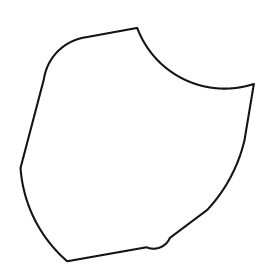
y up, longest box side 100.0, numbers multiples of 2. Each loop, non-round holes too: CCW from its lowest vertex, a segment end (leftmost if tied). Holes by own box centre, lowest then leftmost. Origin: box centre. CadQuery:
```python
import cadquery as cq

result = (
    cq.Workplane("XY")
    .moveTo(-30.0, -50.0)
    .lineTo(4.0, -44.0)
    .threePointArc((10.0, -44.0), (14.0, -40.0))
    .lineTo(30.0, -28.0)
    .threePointArc((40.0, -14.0), (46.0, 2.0))
    .lineTo(50.0, 26.0)
    .threePointArc((20.0, 28.0), (0.0, 50.0))
    .lineTo(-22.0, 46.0)
    .threePointArc((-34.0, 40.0), (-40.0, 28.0))
    .lineTo(-50.0, -10.0)
    .threePointArc((-44.0, -32.0), (-30.0, -50.0))
    .close()
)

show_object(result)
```